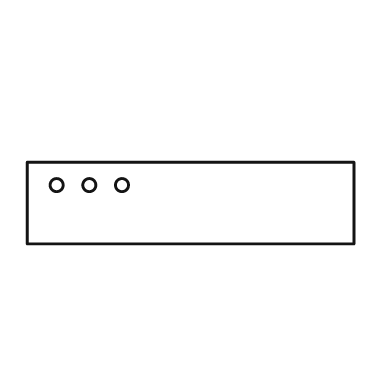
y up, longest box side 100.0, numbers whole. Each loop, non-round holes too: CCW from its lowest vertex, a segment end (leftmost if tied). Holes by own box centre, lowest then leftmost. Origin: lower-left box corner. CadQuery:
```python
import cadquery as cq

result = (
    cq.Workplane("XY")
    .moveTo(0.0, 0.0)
    .lineTo(100.0, 0.0)
    .lineTo(100.0, 25.0)
    .lineTo(0.0, 25.0)
    .close()
    .moveTo(9.0, 18.0)
    .circle(2.0)
    .moveTo(19.0, 18.0)
    .circle(2.0)
    .moveTo(29.0, 18.0)
    .circle(2.0)
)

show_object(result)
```